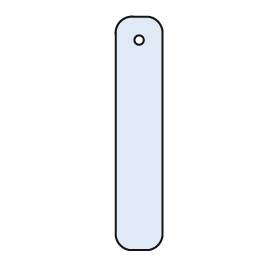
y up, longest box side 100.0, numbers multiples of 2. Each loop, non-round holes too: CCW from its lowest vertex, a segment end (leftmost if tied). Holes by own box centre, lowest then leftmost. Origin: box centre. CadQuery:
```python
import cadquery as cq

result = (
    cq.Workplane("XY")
    .moveTo(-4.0, -50.0)
    .lineTo(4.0, -50.0)
    .threePointArc((8.0, -48.0), (10.0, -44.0))
    .lineTo(10.0, 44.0)
    .threePointArc((8.0, 48.0), (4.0, 50.0))
    .lineTo(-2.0, 50.0)
    .threePointArc((-8.0, 48.0), (-10.0, 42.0))
    .lineTo(-10.0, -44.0)
    .threePointArc((-8.0, -48.0), (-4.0, -50.0))
    .close()
    .moveTo(0.0, 40.0)
    .circle(2.0)
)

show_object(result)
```